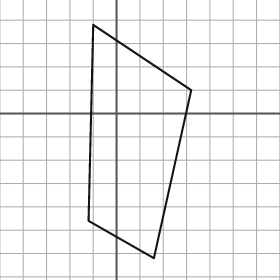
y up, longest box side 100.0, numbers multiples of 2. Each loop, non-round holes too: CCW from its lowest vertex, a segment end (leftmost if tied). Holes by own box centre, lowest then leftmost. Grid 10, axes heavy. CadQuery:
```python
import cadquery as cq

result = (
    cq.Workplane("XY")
    .moveTo(16.0, -62.0)
    .lineTo(32.0, 10.0)
    .lineTo(-10.0, 38.0)
    .lineTo(-12.0, -46.0)
    .close()
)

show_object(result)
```